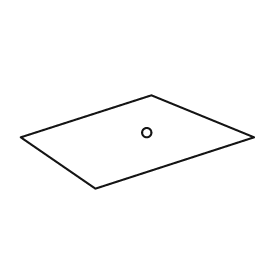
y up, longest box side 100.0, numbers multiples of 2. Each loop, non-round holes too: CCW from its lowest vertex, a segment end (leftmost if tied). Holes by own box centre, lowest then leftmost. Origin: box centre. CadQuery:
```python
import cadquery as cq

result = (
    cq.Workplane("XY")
    .moveTo(-18.0, -20.0)
    .lineTo(50.0, 2.0)
    .lineTo(6.0, 20.0)
    .lineTo(-50.0, 2.0)
    .close()
    .moveTo(4.0, 4.0)
    .circle(2.0)
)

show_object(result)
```